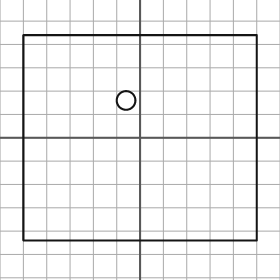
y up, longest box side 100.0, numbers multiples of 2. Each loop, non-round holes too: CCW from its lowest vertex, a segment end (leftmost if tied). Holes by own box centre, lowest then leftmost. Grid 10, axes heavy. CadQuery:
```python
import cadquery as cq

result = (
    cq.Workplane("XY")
    .moveTo(-50.0, -44.0)
    .lineTo(50.0, -44.0)
    .lineTo(50.0, 44.0)
    .lineTo(-50.0, 44.0)
    .close()
    .moveTo(-6.0, 16.0)
    .circle(4.0)
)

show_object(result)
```